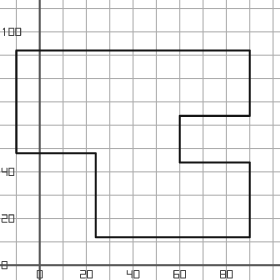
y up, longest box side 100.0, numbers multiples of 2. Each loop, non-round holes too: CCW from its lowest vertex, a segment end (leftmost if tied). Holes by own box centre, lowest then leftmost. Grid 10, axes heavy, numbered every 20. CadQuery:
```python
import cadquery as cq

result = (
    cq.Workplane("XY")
    .moveTo(24.0, 12.0)
    .lineTo(90.0, 12.0)
    .lineTo(90.0, 44.0)
    .lineTo(60.0, 44.0)
    .lineTo(60.0, 64.0)
    .lineTo(90.0, 64.0)
    .lineTo(90.0, 92.0)
    .lineTo(-10.0, 92.0)
    .lineTo(-10.0, 48.0)
    .lineTo(24.0, 48.0)
    .close()
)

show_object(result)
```